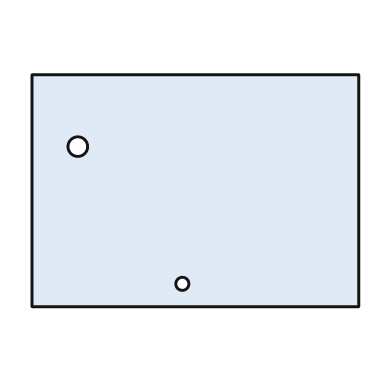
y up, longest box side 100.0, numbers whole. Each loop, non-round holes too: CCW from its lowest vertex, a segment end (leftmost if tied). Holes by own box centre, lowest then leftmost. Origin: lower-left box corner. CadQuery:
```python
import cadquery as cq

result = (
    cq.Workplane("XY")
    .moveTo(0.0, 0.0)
    .lineTo(100.0, 0.0)
    .lineTo(100.0, 71.0)
    .lineTo(0.0, 71.0)
    .close()
    .moveTo(46.0, 7.0)
    .circle(2.0)
    .moveTo(14.0, 49.0)
    .circle(3.0)
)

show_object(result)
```